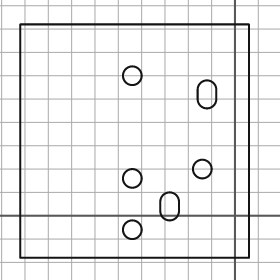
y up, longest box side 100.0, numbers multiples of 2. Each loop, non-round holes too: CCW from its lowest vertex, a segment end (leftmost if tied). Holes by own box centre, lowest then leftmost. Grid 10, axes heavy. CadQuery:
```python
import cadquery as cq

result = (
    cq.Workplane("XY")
    .moveTo(-92.0, -18.0)
    .lineTo(6.0, -18.0)
    .lineTo(6.0, 82.0)
    .lineTo(-92.0, 82.0)
    .close()
    .moveTo(-44.0, -6.0)
    .circle(4.0)
    .moveTo(-32.0, 2.0)
    .threePointArc((-28.0, -2.0), (-24.0, 2.0))
    .lineTo(-24.0, 6.0)
    .threePointArc((-28.0, 10.0), (-32.0, 6.0))
    .close()
    .moveTo(-44.0, 16.0)
    .circle(4.0)
    .moveTo(-14.0, 20.0)
    .circle(4.0)
    .moveTo(-16.0, 50.0)
    .threePointArc((-12.0, 46.0), (-8.0, 50.0))
    .lineTo(-8.0, 54.0)
    .threePointArc((-12.0, 58.0), (-16.0, 54.0))
    .close()
    .moveTo(-44.0, 60.0)
    .circle(4.0)
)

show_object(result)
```